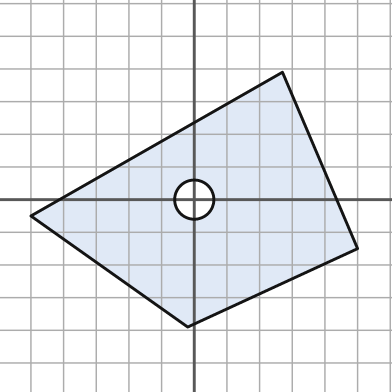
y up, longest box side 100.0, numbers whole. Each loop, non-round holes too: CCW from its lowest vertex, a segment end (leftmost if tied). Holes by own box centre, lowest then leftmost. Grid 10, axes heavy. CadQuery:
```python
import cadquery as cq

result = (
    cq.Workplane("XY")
    .moveTo(-2.0, -39.0)
    .lineTo(50.0, -15.0)
    .lineTo(27.0, 39.0)
    .lineTo(-50.0, -5.0)
    .close()
    .moveTo(0.0, 0.0)
    .circle(6.0)
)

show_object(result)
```